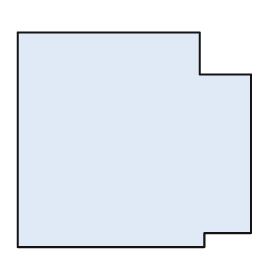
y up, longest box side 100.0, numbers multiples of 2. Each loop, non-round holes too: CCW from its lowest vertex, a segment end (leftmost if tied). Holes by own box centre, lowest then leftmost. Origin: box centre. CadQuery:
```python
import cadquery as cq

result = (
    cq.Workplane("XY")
    .moveTo(-50.0, -46.0)
    .lineTo(30.0, -46.0)
    .lineTo(30.0, -40.0)
    .lineTo(50.0, -40.0)
    .lineTo(50.0, 28.0)
    .lineTo(28.0, 28.0)
    .lineTo(28.0, 46.0)
    .lineTo(-50.0, 46.0)
    .close()
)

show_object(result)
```